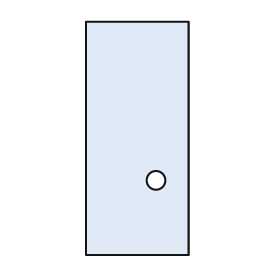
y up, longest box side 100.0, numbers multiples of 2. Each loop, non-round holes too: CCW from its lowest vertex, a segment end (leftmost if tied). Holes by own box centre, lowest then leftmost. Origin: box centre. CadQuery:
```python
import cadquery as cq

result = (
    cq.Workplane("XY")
    .moveTo(-22.0, -50.0)
    .lineTo(22.0, -50.0)
    .lineTo(22.0, 50.0)
    .lineTo(-22.0, 50.0)
    .close()
    .moveTo(8.0, -18.0)
    .circle(4.0)
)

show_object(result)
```